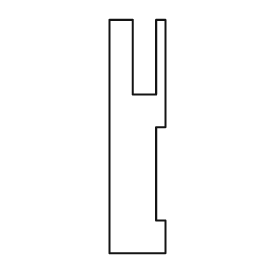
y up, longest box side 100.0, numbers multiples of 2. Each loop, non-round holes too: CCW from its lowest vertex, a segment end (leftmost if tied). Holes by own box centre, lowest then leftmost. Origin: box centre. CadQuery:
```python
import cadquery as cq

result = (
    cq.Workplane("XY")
    .moveTo(-12.0, -50.0)
    .lineTo(12.0, -50.0)
    .lineTo(12.0, -36.0)
    .lineTo(8.0, -36.0)
    .lineTo(8.0, 4.0)
    .lineTo(12.0, 4.0)
    .lineTo(12.0, 50.0)
    .lineTo(8.0, 50.0)
    .lineTo(8.0, 18.0)
    .lineTo(-2.0, 18.0)
    .lineTo(-2.0, 50.0)
    .lineTo(-12.0, 50.0)
    .close()
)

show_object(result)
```